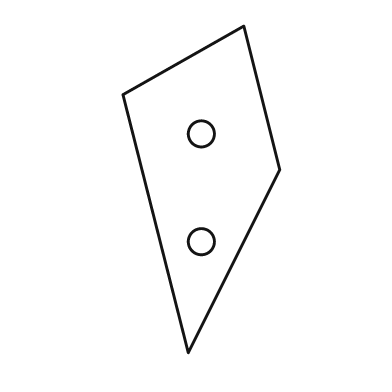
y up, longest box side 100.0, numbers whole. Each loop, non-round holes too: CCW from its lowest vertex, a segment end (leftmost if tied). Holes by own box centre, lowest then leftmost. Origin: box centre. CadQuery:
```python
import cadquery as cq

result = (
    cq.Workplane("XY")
    .moveTo(-4.0, -50.0)
    .lineTo(24.0, 6.0)
    .lineTo(13.0, 50.0)
    .lineTo(-24.0, 29.0)
    .close()
    .moveTo(0.0, -16.0)
    .circle(4.0)
    .moveTo(0.0, 17.0)
    .circle(4.0)
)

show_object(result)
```